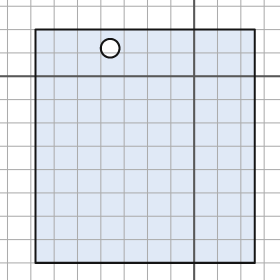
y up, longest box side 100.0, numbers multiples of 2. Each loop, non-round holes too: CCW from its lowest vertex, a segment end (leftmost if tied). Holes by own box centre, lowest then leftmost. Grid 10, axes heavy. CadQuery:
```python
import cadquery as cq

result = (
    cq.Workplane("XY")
    .moveTo(-68.0, -80.0)
    .lineTo(26.0, -80.0)
    .lineTo(26.0, 20.0)
    .lineTo(-68.0, 20.0)
    .close()
    .moveTo(-36.0, 12.0)
    .circle(4.0)
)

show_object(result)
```